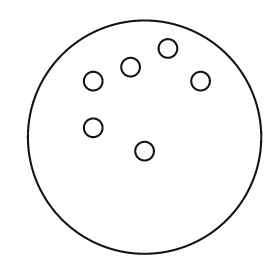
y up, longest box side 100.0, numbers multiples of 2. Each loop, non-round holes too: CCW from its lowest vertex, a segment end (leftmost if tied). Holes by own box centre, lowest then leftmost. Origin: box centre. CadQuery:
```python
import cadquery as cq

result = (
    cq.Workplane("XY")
    .moveTo(0.0, 0.0)
    .circle(50.0)
    .moveTo(0.0, -6.0)
    .circle(4.0)
    .moveTo(-22.0, 4.0)
    .circle(4.0)
    .moveTo(-22.0, 24.0)
    .circle(4.0)
    .moveTo(24.0, 24.0)
    .circle(4.0)
    .moveTo(-6.0, 30.0)
    .circle(4.0)
    .moveTo(10.0, 38.0)
    .circle(4.0)
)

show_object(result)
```